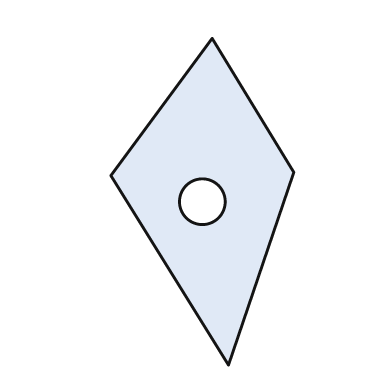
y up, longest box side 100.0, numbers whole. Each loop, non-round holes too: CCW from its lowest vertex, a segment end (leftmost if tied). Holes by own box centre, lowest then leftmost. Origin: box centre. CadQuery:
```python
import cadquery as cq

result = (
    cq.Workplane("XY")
    .moveTo(8.0, -50.0)
    .lineTo(28.0, 9.0)
    .lineTo(3.0, 50.0)
    .lineTo(-28.0, 8.0)
    .close()
    .moveTo(0.0, 0.0)
    .circle(7.0)
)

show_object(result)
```